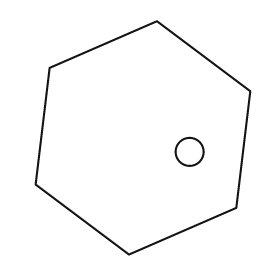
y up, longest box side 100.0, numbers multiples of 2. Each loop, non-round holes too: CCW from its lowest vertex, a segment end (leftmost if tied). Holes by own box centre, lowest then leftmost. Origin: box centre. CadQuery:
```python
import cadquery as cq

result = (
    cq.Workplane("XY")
    .moveTo(-6.0, -50.0)
    .lineTo(40.0, -30.0)
    .lineTo(46.0, 20.0)
    .lineTo(6.0, 50.0)
    .lineTo(-40.0, 30.0)
    .lineTo(-46.0, -20.0)
    .close()
    .moveTo(20.0, -6.0)
    .circle(6.0)
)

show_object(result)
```